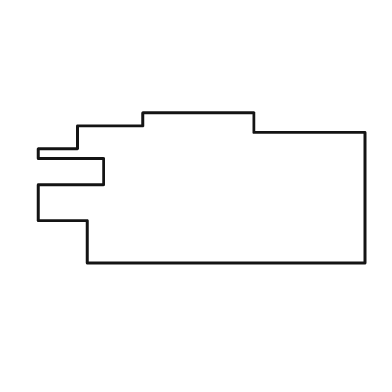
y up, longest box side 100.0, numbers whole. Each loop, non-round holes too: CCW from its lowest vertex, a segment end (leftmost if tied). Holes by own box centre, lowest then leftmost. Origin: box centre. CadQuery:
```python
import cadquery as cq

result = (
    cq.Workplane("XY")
    .moveTo(-35.0, -23.0)
    .lineTo(50.0, -23.0)
    .lineTo(50.0, 17.0)
    .lineTo(16.0, 17.0)
    .lineTo(16.0, 23.0)
    .lineTo(-18.0, 23.0)
    .lineTo(-18.0, 19.0)
    .lineTo(-38.0, 19.0)
    .lineTo(-38.0, 12.0)
    .lineTo(-50.0, 12.0)
    .lineTo(-50.0, 9.0)
    .lineTo(-30.0, 9.0)
    .lineTo(-30.0, 1.0)
    .lineTo(-50.0, 1.0)
    .lineTo(-50.0, -10.0)
    .lineTo(-35.0, -10.0)
    .close()
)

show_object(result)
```